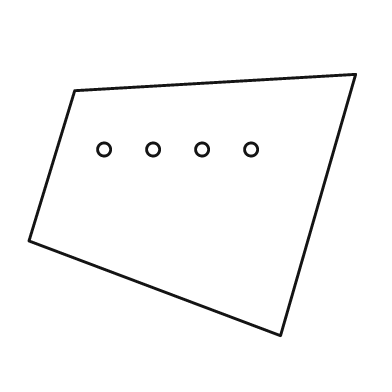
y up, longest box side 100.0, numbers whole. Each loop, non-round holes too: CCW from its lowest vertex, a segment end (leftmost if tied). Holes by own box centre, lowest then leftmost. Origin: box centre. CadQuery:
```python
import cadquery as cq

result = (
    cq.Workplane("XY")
    .moveTo(27.0, -40.0)
    .lineTo(50.0, 40.0)
    .lineTo(-36.0, 35.0)
    .lineTo(-50.0, -11.0)
    .close()
    .moveTo(-27.0, 17.0)
    .circle(2.0)
    .moveTo(-12.0, 17.0)
    .circle(2.0)
    .moveTo(3.0, 17.0)
    .circle(2.0)
    .moveTo(18.0, 17.0)
    .circle(2.0)
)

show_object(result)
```